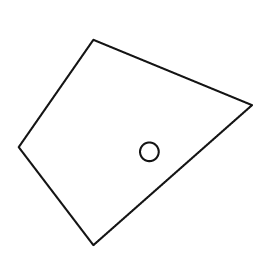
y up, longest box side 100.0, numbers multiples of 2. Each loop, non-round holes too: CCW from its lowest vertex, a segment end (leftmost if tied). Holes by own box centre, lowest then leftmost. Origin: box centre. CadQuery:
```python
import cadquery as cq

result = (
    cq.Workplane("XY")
    .moveTo(-18.0, -44.0)
    .lineTo(50.0, 16.0)
    .lineTo(-18.0, 44.0)
    .lineTo(-50.0, -2.0)
    .close()
    .moveTo(6.0, -4.0)
    .circle(4.0)
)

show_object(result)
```